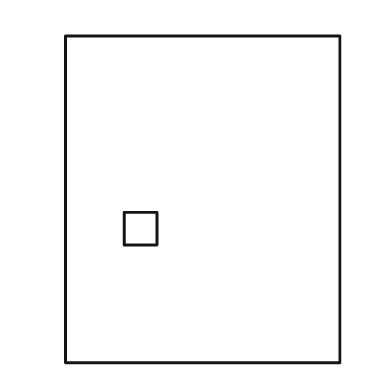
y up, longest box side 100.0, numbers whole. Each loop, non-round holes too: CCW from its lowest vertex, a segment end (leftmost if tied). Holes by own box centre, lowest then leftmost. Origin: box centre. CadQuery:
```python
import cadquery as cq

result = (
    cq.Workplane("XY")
    .moveTo(-42.0, -50.0)
    .lineTo(42.0, -50.0)
    .lineTo(42.0, 50.0)
    .lineTo(-42.0, 50.0)
    .close()
    .moveTo(-24.0, -14.0)
    .lineTo(-14.0, -14.0)
    .lineTo(-14.0, -4.0)
    .lineTo(-24.0, -4.0)
    .close()
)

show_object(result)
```